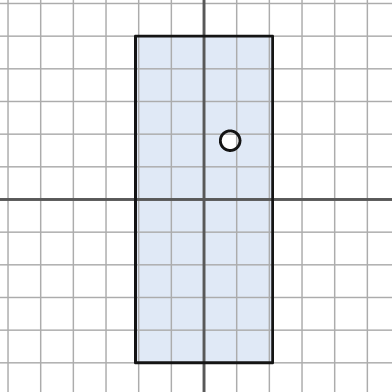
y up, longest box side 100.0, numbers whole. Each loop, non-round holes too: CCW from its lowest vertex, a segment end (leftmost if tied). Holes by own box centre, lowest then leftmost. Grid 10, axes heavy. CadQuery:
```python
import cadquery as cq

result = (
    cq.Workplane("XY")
    .moveTo(-21.0, -50.0)
    .lineTo(21.0, -50.0)
    .lineTo(21.0, 50.0)
    .lineTo(-21.0, 50.0)
    .close()
    .moveTo(8.0, 18.0)
    .circle(3.0)
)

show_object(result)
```